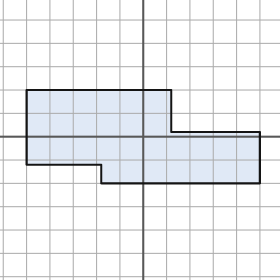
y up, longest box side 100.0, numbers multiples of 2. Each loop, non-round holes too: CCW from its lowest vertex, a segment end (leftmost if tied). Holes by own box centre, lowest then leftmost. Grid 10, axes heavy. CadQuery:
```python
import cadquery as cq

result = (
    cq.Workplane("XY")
    .moveTo(-18.0, -20.0)
    .lineTo(50.0, -20.0)
    .lineTo(50.0, 2.0)
    .lineTo(12.0, 2.0)
    .lineTo(12.0, 20.0)
    .lineTo(-50.0, 20.0)
    .lineTo(-50.0, -12.0)
    .lineTo(-18.0, -12.0)
    .close()
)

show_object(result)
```